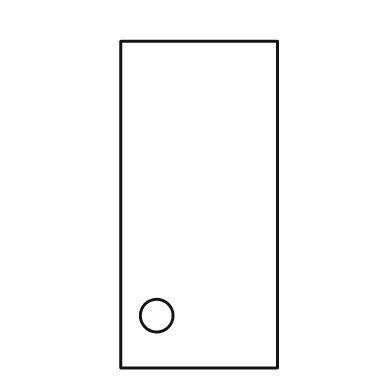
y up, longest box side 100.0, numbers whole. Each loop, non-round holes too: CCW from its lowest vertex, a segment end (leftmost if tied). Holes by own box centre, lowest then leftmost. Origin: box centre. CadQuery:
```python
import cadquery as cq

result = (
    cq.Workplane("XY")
    .moveTo(-24.0, -50.0)
    .lineTo(24.0, -50.0)
    .lineTo(24.0, 50.0)
    .lineTo(-24.0, 50.0)
    .close()
    .moveTo(-13.0, -34.0)
    .circle(5.0)
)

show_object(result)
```